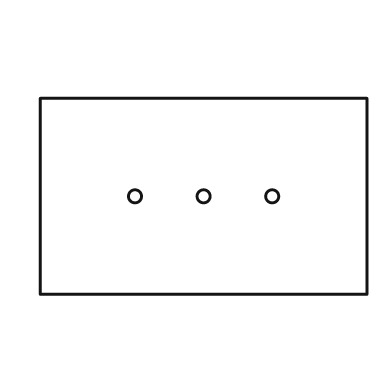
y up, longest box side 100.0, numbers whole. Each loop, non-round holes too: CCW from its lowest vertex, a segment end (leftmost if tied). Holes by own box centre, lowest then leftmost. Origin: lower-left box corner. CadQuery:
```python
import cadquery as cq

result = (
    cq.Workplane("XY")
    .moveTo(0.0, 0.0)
    .lineTo(100.0, 0.0)
    .lineTo(100.0, 60.0)
    .lineTo(0.0, 60.0)
    .close()
    .moveTo(29.0, 30.0)
    .circle(2.0)
    .moveTo(50.0, 30.0)
    .circle(2.0)
    .moveTo(71.0, 30.0)
    .circle(2.0)
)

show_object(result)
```